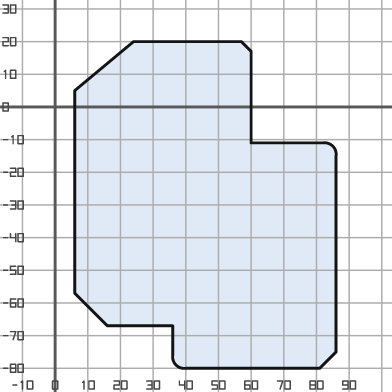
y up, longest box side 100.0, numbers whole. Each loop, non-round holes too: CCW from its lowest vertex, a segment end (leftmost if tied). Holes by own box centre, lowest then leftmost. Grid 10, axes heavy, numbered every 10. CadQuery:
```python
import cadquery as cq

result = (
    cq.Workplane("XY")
    .moveTo(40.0, -80.0)
    .lineTo(81.0, -80.0)
    .lineTo(86.0, -75.0)
    .lineTo(86.0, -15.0)
    .threePointArc((85.0, -12.0), (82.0, -11.0))
    .lineTo(60.0, -11.0)
    .lineTo(60.0, 17.0)
    .lineTo(57.0, 20.0)
    .lineTo(24.0, 20.0)
    .lineTo(6.0, 5.0)
    .lineTo(6.0, -57.0)
    .lineTo(16.0, -67.0)
    .lineTo(36.0, -67.0)
    .lineTo(36.0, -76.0)
    .threePointArc((37.0, -79.0), (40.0, -80.0))
    .close()
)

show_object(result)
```